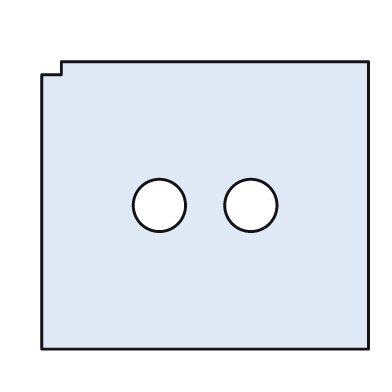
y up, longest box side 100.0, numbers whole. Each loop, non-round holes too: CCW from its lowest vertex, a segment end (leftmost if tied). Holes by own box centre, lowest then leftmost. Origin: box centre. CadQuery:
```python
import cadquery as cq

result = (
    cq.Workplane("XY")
    .moveTo(-50.0, -44.0)
    .lineTo(50.0, -44.0)
    .lineTo(50.0, 44.0)
    .lineTo(-44.0, 44.0)
    .lineTo(-44.0, 40.0)
    .lineTo(-50.0, 40.0)
    .close()
    .moveTo(-14.0, 0.0)
    .circle(8.0)
    .moveTo(14.0, 0.0)
    .circle(8.0)
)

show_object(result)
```